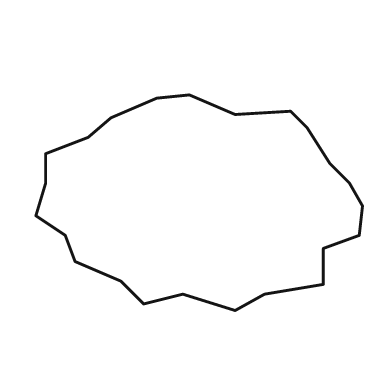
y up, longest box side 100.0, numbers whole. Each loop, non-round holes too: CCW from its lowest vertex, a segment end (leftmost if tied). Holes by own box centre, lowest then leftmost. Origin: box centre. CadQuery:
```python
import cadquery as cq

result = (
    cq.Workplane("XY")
    .moveTo(11.0, -33.0)
    .lineTo(20.0, -28.0)
    .lineTo(38.0, -25.0)
    .lineTo(38.0, -14.0)
    .lineTo(49.0, -10.0)
    .lineTo(50.0, -1.0)
    .lineTo(46.0, 6.0)
    .lineTo(40.0, 12.0)
    .lineTo(33.0, 23.0)
    .lineTo(28.0, 28.0)
    .lineTo(11.0, 27.0)
    .lineTo(-3.0, 33.0)
    .lineTo(-13.0, 32.0)
    .lineTo(-27.0, 26.0)
    .lineTo(-34.0, 20.0)
    .lineTo(-47.0, 15.0)
    .lineTo(-47.0, 6.0)
    .lineTo(-50.0, -4.0)
    .lineTo(-41.0, -10.0)
    .lineTo(-38.0, -18.0)
    .lineTo(-24.0, -24.0)
    .lineTo(-17.0, -31.0)
    .lineTo(-5.0, -28.0)
    .close()
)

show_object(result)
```